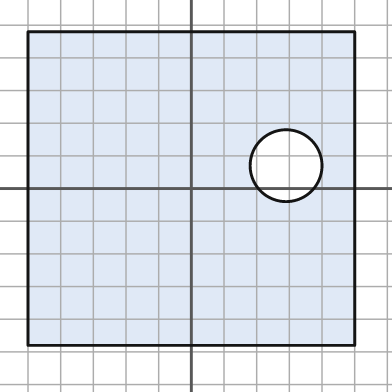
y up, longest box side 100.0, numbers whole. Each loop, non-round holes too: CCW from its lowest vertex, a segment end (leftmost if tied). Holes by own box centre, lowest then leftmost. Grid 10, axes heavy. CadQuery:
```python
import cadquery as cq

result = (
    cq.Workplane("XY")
    .moveTo(-50.0, -48.0)
    .lineTo(50.0, -48.0)
    .lineTo(50.0, 48.0)
    .lineTo(-50.0, 48.0)
    .close()
    .moveTo(29.0, 7.0)
    .circle(11.0)
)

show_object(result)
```